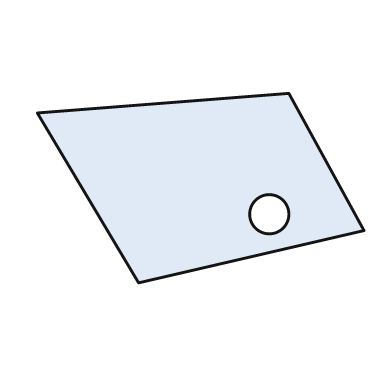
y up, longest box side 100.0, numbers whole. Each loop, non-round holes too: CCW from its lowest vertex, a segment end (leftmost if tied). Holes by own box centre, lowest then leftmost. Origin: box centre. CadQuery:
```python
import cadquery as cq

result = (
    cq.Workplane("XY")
    .moveTo(-19.0, -29.0)
    .lineTo(50.0, -13.0)
    .lineTo(27.0, 29.0)
    .lineTo(-50.0, 23.0)
    .close()
    .moveTo(21.0, -8.0)
    .circle(6.0)
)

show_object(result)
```